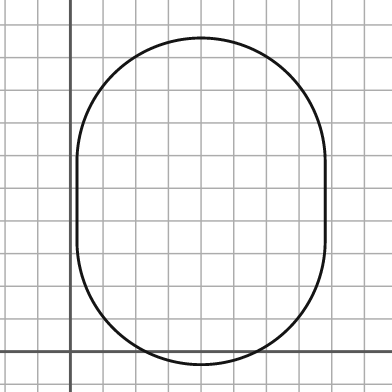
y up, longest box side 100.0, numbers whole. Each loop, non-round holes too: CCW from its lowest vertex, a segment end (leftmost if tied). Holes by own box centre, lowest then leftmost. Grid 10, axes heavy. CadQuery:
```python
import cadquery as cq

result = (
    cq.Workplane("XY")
    .moveTo(2.0, 34.0)
    .threePointArc((40.0, -4.0), (78.0, 34.0))
    .lineTo(78.0, 58.0)
    .threePointArc((40.0, 96.0), (2.0, 58.0))
    .close()
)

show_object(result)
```